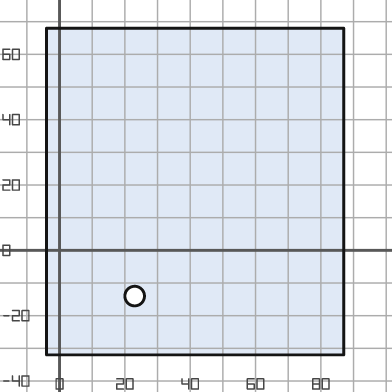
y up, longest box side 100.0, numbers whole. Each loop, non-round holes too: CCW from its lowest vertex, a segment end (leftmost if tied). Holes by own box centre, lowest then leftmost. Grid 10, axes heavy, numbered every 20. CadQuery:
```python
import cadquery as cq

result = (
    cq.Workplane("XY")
    .moveTo(-4.0, -32.0)
    .lineTo(87.0, -32.0)
    .lineTo(87.0, 68.0)
    .lineTo(-4.0, 68.0)
    .close()
    .moveTo(23.0, -14.0)
    .circle(3.0)
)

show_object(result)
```